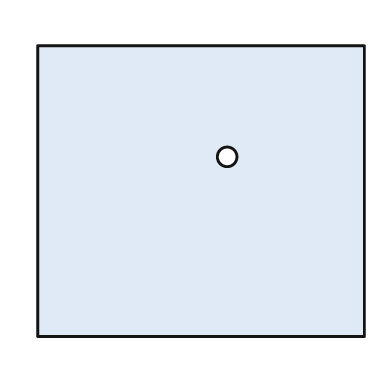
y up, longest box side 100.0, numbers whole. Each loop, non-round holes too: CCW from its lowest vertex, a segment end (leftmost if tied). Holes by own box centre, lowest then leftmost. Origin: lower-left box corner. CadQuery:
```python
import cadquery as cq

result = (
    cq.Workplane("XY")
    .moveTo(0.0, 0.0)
    .lineTo(100.0, 0.0)
    .lineTo(100.0, 89.0)
    .lineTo(0.0, 89.0)
    .close()
    .moveTo(58.0, 55.0)
    .circle(3.0)
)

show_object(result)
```